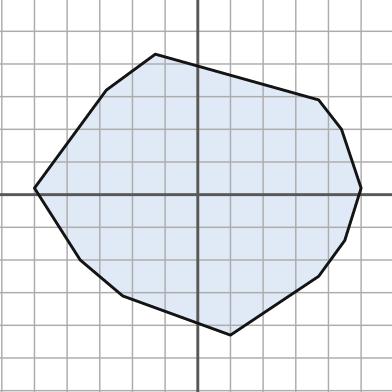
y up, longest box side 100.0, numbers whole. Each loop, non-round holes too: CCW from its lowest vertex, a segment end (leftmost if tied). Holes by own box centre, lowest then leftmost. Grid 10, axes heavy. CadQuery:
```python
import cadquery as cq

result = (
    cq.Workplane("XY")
    .moveTo(10.0, -43.0)
    .lineTo(37.0, -25.0)
    .lineTo(45.0, -14.0)
    .lineTo(50.0, 2.0)
    .lineTo(44.0, 20.0)
    .lineTo(37.0, 29.0)
    .lineTo(-13.0, 43.0)
    .lineTo(-28.0, 32.0)
    .lineTo(-50.0, 2.0)
    .lineTo(-36.0, -20.0)
    .lineTo(-23.0, -31.0)
    .close()
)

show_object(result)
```